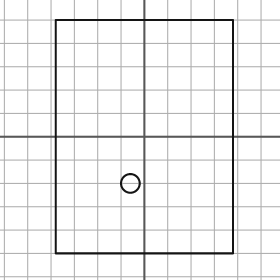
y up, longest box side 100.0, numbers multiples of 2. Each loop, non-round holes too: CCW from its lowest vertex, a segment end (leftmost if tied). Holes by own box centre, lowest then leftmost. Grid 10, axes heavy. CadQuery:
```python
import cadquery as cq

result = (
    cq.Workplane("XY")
    .moveTo(-38.0, -50.0)
    .lineTo(38.0, -50.0)
    .lineTo(38.0, 50.0)
    .lineTo(-38.0, 50.0)
    .close()
    .moveTo(-6.0, -20.0)
    .circle(4.0)
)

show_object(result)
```